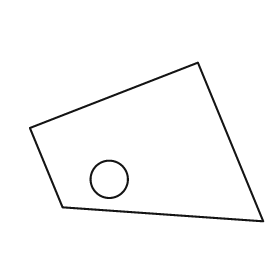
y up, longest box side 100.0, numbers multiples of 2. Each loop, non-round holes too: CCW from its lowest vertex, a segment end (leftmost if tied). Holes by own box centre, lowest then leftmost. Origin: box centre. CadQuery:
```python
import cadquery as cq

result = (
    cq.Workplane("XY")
    .moveTo(50.0, -34.0)
    .lineTo(22.0, 34.0)
    .lineTo(-50.0, 6.0)
    .lineTo(-36.0, -28.0)
    .close()
    .moveTo(-16.0, -16.0)
    .circle(8.0)
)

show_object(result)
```